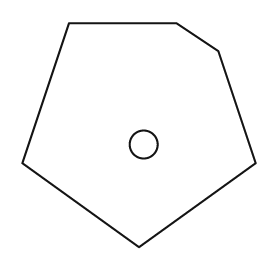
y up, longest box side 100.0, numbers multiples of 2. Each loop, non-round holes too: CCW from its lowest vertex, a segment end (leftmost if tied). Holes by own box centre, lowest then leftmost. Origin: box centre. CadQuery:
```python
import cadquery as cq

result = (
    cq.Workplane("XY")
    .moveTo(0.0, -48.0)
    .lineTo(50.0, -12.0)
    .lineTo(34.0, 36.0)
    .lineTo(16.0, 48.0)
    .lineTo(-30.0, 48.0)
    .lineTo(-50.0, -12.0)
    .close()
    .moveTo(2.0, -4.0)
    .circle(6.0)
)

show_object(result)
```